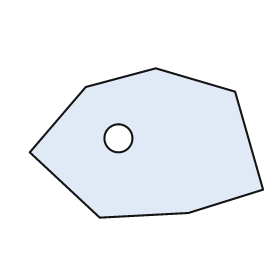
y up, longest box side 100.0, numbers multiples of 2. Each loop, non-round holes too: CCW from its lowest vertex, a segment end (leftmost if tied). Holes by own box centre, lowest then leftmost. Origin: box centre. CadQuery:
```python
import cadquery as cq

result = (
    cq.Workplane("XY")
    .moveTo(-20.0, -32.0)
    .lineTo(18.0, -30.0)
    .lineTo(50.0, -20.0)
    .lineTo(38.0, 22.0)
    .lineTo(4.0, 32.0)
    .lineTo(-26.0, 24.0)
    .lineTo(-50.0, -4.0)
    .close()
    .moveTo(-12.0, 2.0)
    .circle(6.0)
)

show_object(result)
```